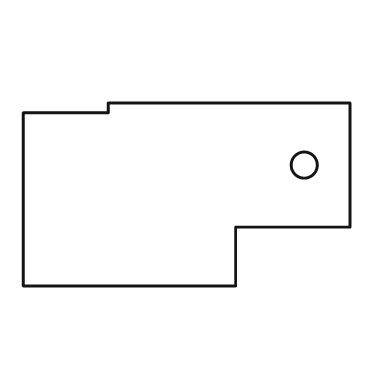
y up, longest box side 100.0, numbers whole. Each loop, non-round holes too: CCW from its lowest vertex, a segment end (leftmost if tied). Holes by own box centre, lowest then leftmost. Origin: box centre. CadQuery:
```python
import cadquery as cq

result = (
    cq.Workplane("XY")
    .moveTo(-50.0, -28.0)
    .lineTo(15.0, -28.0)
    .lineTo(15.0, -10.0)
    .lineTo(50.0, -10.0)
    .lineTo(50.0, 28.0)
    .lineTo(-24.0, 28.0)
    .lineTo(-24.0, 25.0)
    .lineTo(-50.0, 25.0)
    .close()
    .moveTo(36.0, 9.0)
    .circle(4.0)
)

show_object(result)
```